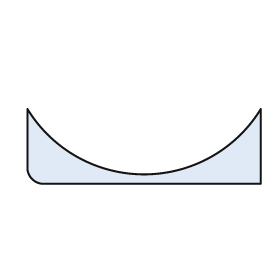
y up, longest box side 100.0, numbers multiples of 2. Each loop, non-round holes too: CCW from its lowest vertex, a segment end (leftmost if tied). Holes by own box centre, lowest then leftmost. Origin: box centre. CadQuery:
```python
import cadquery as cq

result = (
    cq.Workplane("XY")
    .moveTo(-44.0, -16.0)
    .lineTo(50.0, -16.0)
    .lineTo(50.0, 16.0)
    .threePointArc((0.0, -12.0), (-50.0, 16.0))
    .lineTo(-50.0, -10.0)
    .threePointArc((-48.0, -14.0), (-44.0, -16.0))
    .close()
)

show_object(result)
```